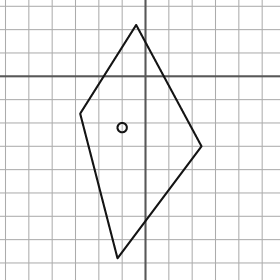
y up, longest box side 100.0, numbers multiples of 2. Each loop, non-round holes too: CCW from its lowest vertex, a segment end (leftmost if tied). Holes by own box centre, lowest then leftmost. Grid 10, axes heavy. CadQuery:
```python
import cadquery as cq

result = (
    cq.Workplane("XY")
    .moveTo(-12.0, -78.0)
    .lineTo(24.0, -30.0)
    .lineTo(-4.0, 22.0)
    .lineTo(-28.0, -16.0)
    .close()
    .moveTo(-10.0, -22.0)
    .circle(2.0)
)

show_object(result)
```